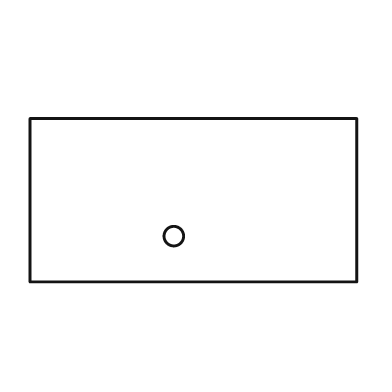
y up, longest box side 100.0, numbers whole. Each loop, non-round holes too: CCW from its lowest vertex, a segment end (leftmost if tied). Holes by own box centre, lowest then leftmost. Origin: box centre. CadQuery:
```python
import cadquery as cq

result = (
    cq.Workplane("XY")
    .moveTo(-50.0, -25.0)
    .lineTo(50.0, -25.0)
    .lineTo(50.0, 25.0)
    .lineTo(-50.0, 25.0)
    .close()
    .moveTo(-6.0, -11.0)
    .circle(3.0)
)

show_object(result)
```